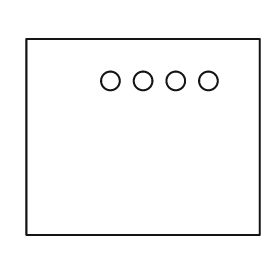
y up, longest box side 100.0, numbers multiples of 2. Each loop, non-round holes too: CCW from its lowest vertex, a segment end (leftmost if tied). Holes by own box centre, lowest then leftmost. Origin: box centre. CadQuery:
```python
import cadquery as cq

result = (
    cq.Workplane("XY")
    .moveTo(-50.0, -42.0)
    .lineTo(50.0, -42.0)
    .lineTo(50.0, 42.0)
    .lineTo(-50.0, 42.0)
    .close()
    .moveTo(-14.0, 24.0)
    .circle(4.0)
    .moveTo(0.0, 24.0)
    .circle(4.0)
    .moveTo(14.0, 24.0)
    .circle(4.0)
    .moveTo(28.0, 24.0)
    .circle(4.0)
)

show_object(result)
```